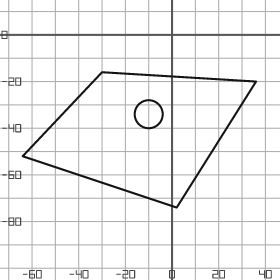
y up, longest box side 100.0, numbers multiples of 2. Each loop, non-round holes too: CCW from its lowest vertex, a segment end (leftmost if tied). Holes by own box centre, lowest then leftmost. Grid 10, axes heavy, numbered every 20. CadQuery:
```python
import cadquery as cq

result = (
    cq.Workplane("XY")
    .moveTo(2.0, -74.0)
    .lineTo(36.0, -20.0)
    .lineTo(-30.0, -16.0)
    .lineTo(-64.0, -52.0)
    .close()
    .moveTo(-10.0, -34.0)
    .circle(6.0)
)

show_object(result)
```